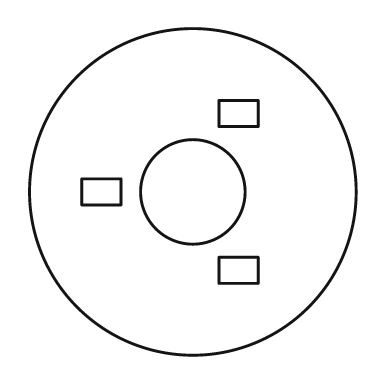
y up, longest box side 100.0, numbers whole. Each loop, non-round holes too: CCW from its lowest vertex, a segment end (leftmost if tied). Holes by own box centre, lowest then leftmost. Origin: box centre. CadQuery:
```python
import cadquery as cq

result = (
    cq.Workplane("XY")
    .moveTo(0.0, 0.0)
    .circle(50.0)
    .moveTo(8.0, -28.0)
    .lineTo(20.0, -28.0)
    .lineTo(20.0, -20.0)
    .lineTo(8.0, -20.0)
    .close()
    .moveTo(-34.0, -4.0)
    .lineTo(-22.0, -4.0)
    .lineTo(-22.0, 4.0)
    .lineTo(-34.0, 4.0)
    .close()
    .moveTo(0.0, 0.0)
    .circle(16.0)
    .moveTo(8.0, 20.0)
    .lineTo(20.0, 20.0)
    .lineTo(20.0, 28.0)
    .lineTo(8.0, 28.0)
    .close()
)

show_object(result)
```